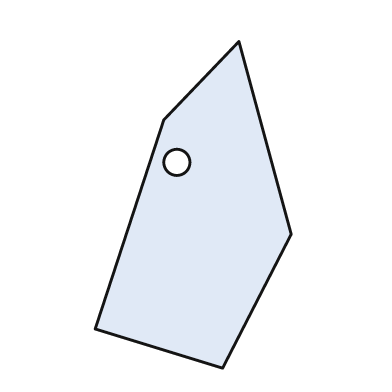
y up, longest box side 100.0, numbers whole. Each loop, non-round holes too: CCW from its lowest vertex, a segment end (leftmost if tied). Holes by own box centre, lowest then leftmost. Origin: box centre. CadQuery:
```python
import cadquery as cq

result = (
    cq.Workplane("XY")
    .moveTo(9.0, -50.0)
    .lineTo(30.0, -9.0)
    .lineTo(14.0, 50.0)
    .lineTo(-9.0, 26.0)
    .lineTo(-30.0, -38.0)
    .close()
    .moveTo(-5.0, 13.0)
    .circle(4.0)
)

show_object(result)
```